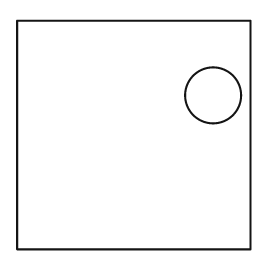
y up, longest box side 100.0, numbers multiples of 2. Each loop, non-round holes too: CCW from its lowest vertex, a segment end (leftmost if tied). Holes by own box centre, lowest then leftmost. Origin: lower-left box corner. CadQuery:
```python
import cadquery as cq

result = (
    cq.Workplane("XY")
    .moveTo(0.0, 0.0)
    .lineTo(100.0, 0.0)
    .lineTo(100.0, 98.0)
    .lineTo(0.0, 98.0)
    .close()
    .moveTo(84.0, 66.0)
    .circle(12.0)
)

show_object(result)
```